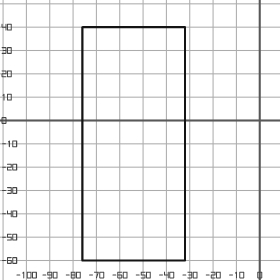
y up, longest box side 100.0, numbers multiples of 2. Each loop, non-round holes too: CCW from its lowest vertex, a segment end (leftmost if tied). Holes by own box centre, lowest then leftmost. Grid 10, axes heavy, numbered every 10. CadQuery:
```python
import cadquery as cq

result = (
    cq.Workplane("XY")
    .moveTo(-76.0, -60.0)
    .lineTo(-32.0, -60.0)
    .lineTo(-32.0, 40.0)
    .lineTo(-76.0, 40.0)
    .close()
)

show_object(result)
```